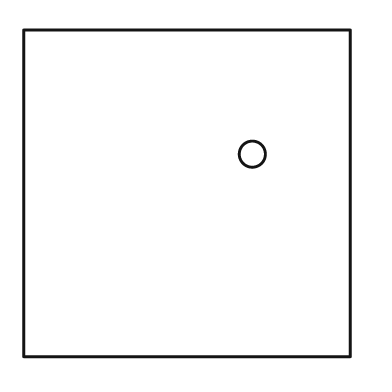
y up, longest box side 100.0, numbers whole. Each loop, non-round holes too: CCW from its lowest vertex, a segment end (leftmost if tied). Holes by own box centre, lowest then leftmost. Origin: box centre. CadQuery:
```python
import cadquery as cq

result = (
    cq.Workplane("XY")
    .moveTo(-50.0, -50.0)
    .lineTo(50.0, -50.0)
    .lineTo(50.0, 50.0)
    .lineTo(-50.0, 50.0)
    .close()
    .moveTo(20.0, 12.0)
    .circle(4.0)
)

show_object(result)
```